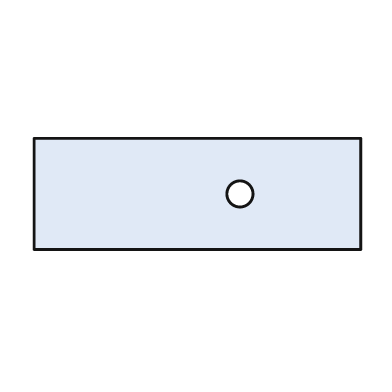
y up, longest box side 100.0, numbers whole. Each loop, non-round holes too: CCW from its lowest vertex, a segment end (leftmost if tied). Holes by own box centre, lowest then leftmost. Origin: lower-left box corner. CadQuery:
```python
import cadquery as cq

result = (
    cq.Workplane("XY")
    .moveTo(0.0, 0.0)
    .lineTo(100.0, 0.0)
    .lineTo(100.0, 34.0)
    .lineTo(0.0, 34.0)
    .close()
    .moveTo(63.0, 17.0)
    .circle(4.0)
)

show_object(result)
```